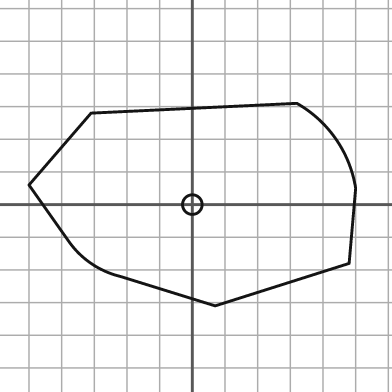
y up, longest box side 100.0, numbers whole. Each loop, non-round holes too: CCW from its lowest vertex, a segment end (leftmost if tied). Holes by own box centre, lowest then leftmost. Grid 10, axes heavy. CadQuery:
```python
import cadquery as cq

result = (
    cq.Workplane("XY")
    .moveTo(7.0, -31.0)
    .lineTo(48.0, -18.0)
    .lineTo(50.0, 5.0)
    .threePointArc((44.0, 20.0), (32.0, 31.0))
    .lineTo(-31.0, 28.0)
    .lineTo(-50.0, 6.0)
    .lineTo(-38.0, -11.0)
    .threePointArc((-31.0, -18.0), (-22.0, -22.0))
    .close()
    .moveTo(0.0, 0.0)
    .circle(3.0)
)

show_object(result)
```